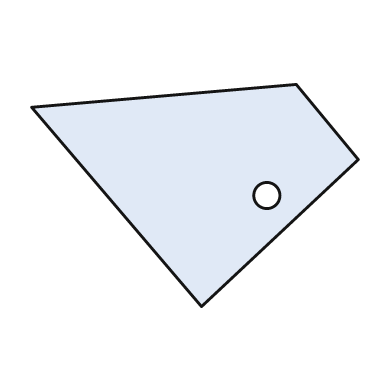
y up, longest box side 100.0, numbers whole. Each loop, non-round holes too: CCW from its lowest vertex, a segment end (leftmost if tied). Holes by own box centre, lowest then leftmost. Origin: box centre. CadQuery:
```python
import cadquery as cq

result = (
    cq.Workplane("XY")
    .moveTo(2.0, -34.0)
    .lineTo(50.0, 11.0)
    .lineTo(31.0, 34.0)
    .lineTo(-50.0, 27.0)
    .close()
    .moveTo(22.0, 0.0)
    .circle(4.0)
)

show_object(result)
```